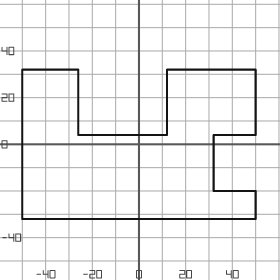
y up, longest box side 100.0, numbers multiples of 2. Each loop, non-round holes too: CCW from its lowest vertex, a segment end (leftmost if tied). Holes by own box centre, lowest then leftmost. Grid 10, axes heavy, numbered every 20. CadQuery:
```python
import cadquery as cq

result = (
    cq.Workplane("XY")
    .moveTo(-50.0, -32.0)
    .lineTo(50.0, -32.0)
    .lineTo(50.0, -20.0)
    .lineTo(32.0, -20.0)
    .lineTo(32.0, 4.0)
    .lineTo(50.0, 4.0)
    .lineTo(50.0, 32.0)
    .lineTo(12.0, 32.0)
    .lineTo(12.0, 4.0)
    .lineTo(-26.0, 4.0)
    .lineTo(-26.0, 32.0)
    .lineTo(-50.0, 32.0)
    .close()
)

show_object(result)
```